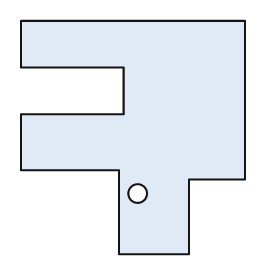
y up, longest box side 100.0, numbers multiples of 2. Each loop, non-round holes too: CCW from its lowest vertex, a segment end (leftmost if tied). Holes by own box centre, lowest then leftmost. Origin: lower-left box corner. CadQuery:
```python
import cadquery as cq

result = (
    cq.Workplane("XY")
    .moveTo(42.0, 0.0)
    .lineTo(72.0, 0.0)
    .lineTo(72.0, 32.0)
    .lineTo(96.0, 32.0)
    .lineTo(96.0, 100.0)
    .lineTo(0.0, 100.0)
    .lineTo(0.0, 80.0)
    .lineTo(44.0, 80.0)
    .lineTo(44.0, 60.0)
    .lineTo(0.0, 60.0)
    .lineTo(0.0, 36.0)
    .lineTo(42.0, 36.0)
    .close()
    .moveTo(50.0, 26.0)
    .circle(4.0)
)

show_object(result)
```